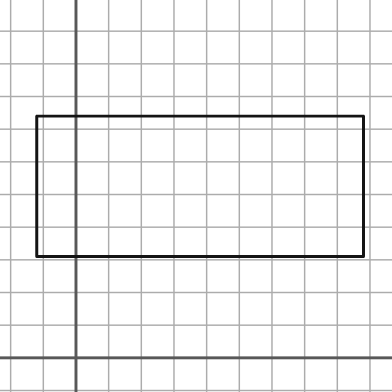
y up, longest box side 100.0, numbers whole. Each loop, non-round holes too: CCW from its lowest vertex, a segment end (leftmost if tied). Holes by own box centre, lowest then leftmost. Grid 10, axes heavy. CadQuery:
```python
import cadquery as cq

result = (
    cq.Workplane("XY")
    .moveTo(-12.0, 31.0)
    .lineTo(88.0, 31.0)
    .lineTo(88.0, 74.0)
    .lineTo(-12.0, 74.0)
    .close()
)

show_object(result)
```